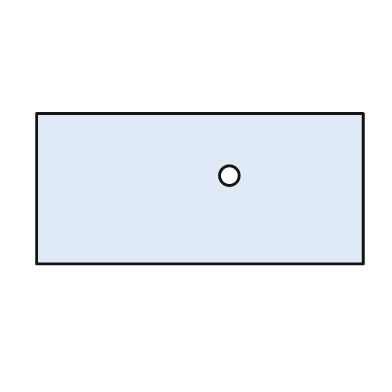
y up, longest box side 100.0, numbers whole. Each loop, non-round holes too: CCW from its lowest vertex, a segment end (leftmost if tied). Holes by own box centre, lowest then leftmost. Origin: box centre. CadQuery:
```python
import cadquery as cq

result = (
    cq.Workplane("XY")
    .moveTo(-50.0, -23.0)
    .lineTo(50.0, -23.0)
    .lineTo(50.0, 23.0)
    .lineTo(-50.0, 23.0)
    .close()
    .moveTo(9.0, 4.0)
    .circle(3.0)
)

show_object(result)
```